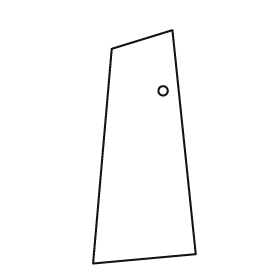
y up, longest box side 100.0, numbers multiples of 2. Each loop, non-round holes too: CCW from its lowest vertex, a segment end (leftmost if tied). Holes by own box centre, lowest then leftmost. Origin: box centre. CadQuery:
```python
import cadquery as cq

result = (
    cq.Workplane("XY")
    .moveTo(-22.0, -50.0)
    .lineTo(22.0, -46.0)
    .lineTo(12.0, 50.0)
    .lineTo(-14.0, 42.0)
    .close()
    .moveTo(8.0, 24.0)
    .circle(2.0)
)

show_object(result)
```